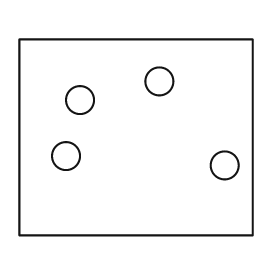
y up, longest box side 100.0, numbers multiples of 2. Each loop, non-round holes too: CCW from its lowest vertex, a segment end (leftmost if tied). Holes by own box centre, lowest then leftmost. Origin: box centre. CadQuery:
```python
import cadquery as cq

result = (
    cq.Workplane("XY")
    .moveTo(-50.0, -42.0)
    .lineTo(50.0, -42.0)
    .lineTo(50.0, 42.0)
    .lineTo(-50.0, 42.0)
    .close()
    .moveTo(38.0, -12.0)
    .circle(6.0)
    .moveTo(-30.0, -8.0)
    .circle(6.0)
    .moveTo(-24.0, 16.0)
    .circle(6.0)
    .moveTo(10.0, 24.0)
    .circle(6.0)
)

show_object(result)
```